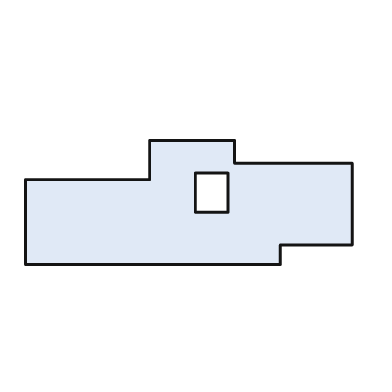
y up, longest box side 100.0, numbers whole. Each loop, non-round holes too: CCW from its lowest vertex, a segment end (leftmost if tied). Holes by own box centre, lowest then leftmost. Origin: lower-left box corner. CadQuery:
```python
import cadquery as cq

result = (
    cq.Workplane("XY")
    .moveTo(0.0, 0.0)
    .lineTo(78.0, 0.0)
    .lineTo(78.0, 6.0)
    .lineTo(100.0, 6.0)
    .lineTo(100.0, 31.0)
    .lineTo(64.0, 31.0)
    .lineTo(64.0, 38.0)
    .lineTo(38.0, 38.0)
    .lineTo(38.0, 26.0)
    .lineTo(0.0, 26.0)
    .close()
    .moveTo(52.0, 16.0)
    .lineTo(62.0, 16.0)
    .lineTo(62.0, 28.0)
    .lineTo(52.0, 28.0)
    .close()
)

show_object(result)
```